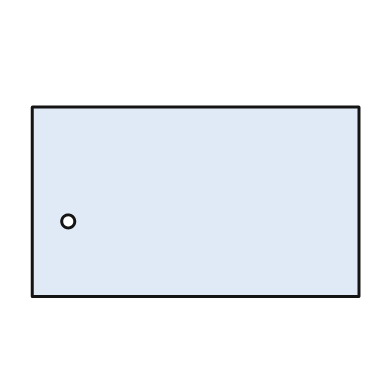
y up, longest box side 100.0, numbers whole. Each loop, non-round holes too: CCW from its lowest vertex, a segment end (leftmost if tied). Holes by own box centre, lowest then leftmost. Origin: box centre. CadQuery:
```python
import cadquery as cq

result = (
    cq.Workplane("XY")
    .moveTo(-50.0, -29.0)
    .lineTo(50.0, -29.0)
    .lineTo(50.0, 29.0)
    .lineTo(-50.0, 29.0)
    .close()
    .moveTo(-39.0, -6.0)
    .circle(2.0)
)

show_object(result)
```